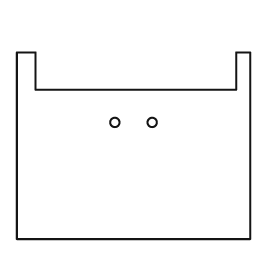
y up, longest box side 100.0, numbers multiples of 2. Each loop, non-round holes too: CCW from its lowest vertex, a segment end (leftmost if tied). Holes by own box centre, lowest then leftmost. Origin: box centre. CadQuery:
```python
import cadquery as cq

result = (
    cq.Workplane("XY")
    .moveTo(-50.0, -40.0)
    .lineTo(50.0, -40.0)
    .lineTo(50.0, 40.0)
    .lineTo(44.0, 40.0)
    .lineTo(44.0, 24.0)
    .lineTo(-42.0, 24.0)
    .lineTo(-42.0, 40.0)
    .lineTo(-50.0, 40.0)
    .close()
    .moveTo(-8.0, 10.0)
    .circle(2.0)
    .moveTo(8.0, 10.0)
    .circle(2.0)
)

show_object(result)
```